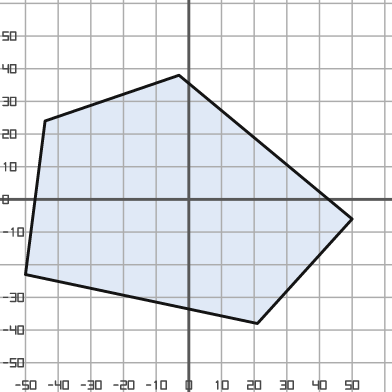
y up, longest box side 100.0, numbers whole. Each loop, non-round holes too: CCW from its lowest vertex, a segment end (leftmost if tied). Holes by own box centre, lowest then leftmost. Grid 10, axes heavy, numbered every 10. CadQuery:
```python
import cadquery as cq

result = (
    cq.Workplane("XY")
    .moveTo(21.0, -38.0)
    .lineTo(50.0, -6.0)
    .lineTo(-3.0, 38.0)
    .lineTo(-44.0, 24.0)
    .lineTo(-50.0, -23.0)
    .close()
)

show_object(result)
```